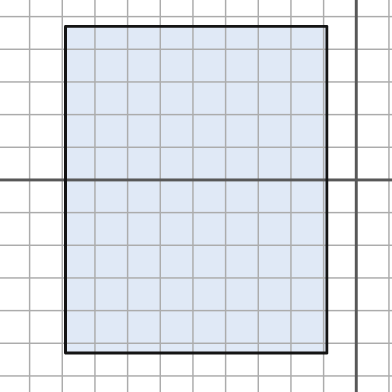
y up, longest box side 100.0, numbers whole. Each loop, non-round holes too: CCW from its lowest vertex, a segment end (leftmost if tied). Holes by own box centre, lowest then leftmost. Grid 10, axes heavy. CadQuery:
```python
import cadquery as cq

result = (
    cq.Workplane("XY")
    .moveTo(-89.0, -53.0)
    .lineTo(-9.0, -53.0)
    .lineTo(-9.0, 47.0)
    .lineTo(-89.0, 47.0)
    .close()
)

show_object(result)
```